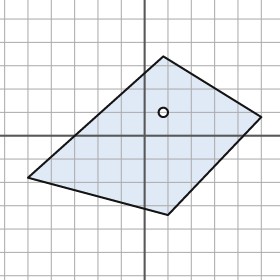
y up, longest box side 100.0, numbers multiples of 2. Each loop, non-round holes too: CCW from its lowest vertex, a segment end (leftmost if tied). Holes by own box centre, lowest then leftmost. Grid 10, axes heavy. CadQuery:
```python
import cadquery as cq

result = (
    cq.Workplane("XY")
    .moveTo(10.0, -34.0)
    .lineTo(50.0, 8.0)
    .lineTo(8.0, 34.0)
    .lineTo(-50.0, -18.0)
    .close()
    .moveTo(8.0, 10.0)
    .circle(2.0)
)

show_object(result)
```